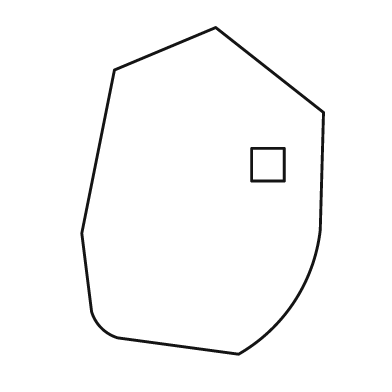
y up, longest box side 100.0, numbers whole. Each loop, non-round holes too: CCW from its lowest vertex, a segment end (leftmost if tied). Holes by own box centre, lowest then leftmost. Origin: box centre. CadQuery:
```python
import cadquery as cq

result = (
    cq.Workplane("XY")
    .moveTo(11.0, -50.0)
    .threePointArc((28.0, -34.0), (36.0, -12.0))
    .lineTo(37.0, 24.0)
    .lineTo(4.0, 50.0)
    .lineTo(-27.0, 37.0)
    .lineTo(-37.0, -13.0)
    .lineTo(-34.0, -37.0)
    .threePointArc((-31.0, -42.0), (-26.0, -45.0))
    .close()
    .moveTo(15.0, 3.0)
    .lineTo(25.0, 3.0)
    .lineTo(25.0, 13.0)
    .lineTo(15.0, 13.0)
    .close()
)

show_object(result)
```